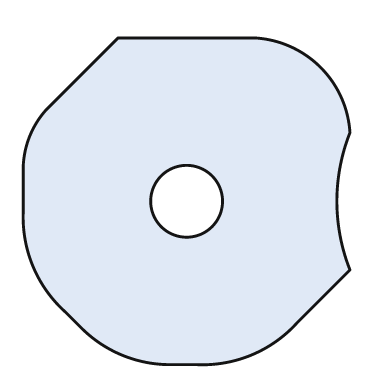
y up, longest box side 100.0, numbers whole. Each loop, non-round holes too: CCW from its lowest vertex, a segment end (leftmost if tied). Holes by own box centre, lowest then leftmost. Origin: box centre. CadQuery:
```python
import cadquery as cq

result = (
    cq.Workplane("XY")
    .moveTo(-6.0, -50.0)
    .lineTo(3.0, -50.0)
    .threePointArc((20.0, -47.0), (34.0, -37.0))
    .lineTo(50.0, -21.0)
    .threePointArc((46.0, 0.0), (50.0, 21.0))
    .threePointArc((41.0, 41.0), (21.0, 50.0))
    .lineTo(-21.0, 50.0)
    .lineTo(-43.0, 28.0)
    .threePointArc((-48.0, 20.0), (-50.0, 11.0))
    .lineTo(-50.0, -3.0)
    .threePointArc((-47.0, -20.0), (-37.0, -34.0))
    .lineTo(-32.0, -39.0)
    .threePointArc((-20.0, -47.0), (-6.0, -50.0))
    .close()
    .moveTo(0.0, 0.0)
    .circle(11.0)
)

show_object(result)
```